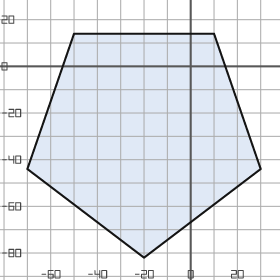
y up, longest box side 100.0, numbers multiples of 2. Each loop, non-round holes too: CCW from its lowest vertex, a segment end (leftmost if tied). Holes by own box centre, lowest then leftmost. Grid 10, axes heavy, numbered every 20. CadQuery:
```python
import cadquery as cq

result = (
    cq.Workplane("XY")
    .moveTo(-20.0, -82.0)
    .lineTo(30.0, -44.0)
    .lineTo(10.0, 14.0)
    .lineTo(-50.0, 14.0)
    .lineTo(-70.0, -44.0)
    .close()
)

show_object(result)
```